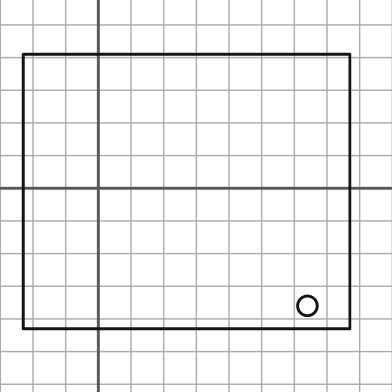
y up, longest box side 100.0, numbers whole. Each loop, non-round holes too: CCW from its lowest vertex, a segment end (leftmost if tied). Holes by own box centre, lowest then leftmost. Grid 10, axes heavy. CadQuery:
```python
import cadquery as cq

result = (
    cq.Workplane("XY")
    .moveTo(-23.0, -43.0)
    .lineTo(77.0, -43.0)
    .lineTo(77.0, 41.0)
    .lineTo(-23.0, 41.0)
    .close()
    .moveTo(64.0, -36.0)
    .circle(3.0)
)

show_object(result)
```